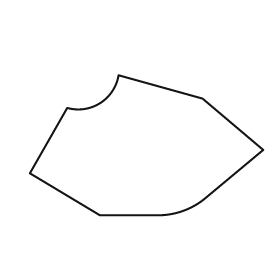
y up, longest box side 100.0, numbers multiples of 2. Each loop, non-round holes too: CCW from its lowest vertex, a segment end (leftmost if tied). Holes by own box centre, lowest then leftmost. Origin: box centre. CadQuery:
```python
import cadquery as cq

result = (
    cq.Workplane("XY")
    .moveTo(-20.0, -30.0)
    .lineTo(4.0, -30.0)
    .threePointArc((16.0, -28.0), (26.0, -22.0))
    .lineTo(50.0, -2.0)
    .lineTo(24.0, 20.0)
    .lineTo(-12.0, 30.0)
    .threePointArc((-20.0, 18.0), (-34.0, 16.0))
    .lineTo(-50.0, -12.0)
    .close()
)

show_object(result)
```